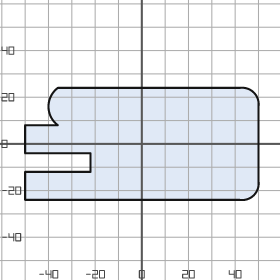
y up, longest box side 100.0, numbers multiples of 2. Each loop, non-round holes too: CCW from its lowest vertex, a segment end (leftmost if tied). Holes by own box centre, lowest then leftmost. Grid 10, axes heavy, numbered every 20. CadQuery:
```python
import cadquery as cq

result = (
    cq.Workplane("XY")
    .moveTo(-50.0, -24.0)
    .lineTo(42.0, -24.0)
    .threePointArc((48.0, -22.0), (50.0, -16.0))
    .lineTo(50.0, 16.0)
    .threePointArc((48.0, 22.0), (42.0, 24.0))
    .lineTo(-36.0, 24.0)
    .threePointArc((-40.0, 16.0), (-36.0, 8.0))
    .lineTo(-50.0, 8.0)
    .lineTo(-50.0, -4.0)
    .lineTo(-22.0, -4.0)
    .lineTo(-22.0, -12.0)
    .lineTo(-50.0, -12.0)
    .close()
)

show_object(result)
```